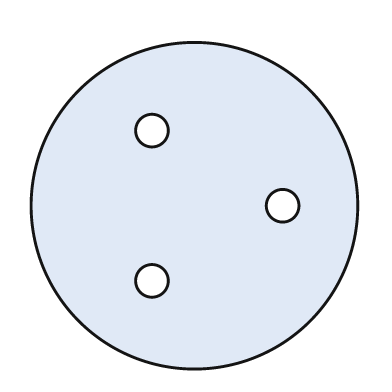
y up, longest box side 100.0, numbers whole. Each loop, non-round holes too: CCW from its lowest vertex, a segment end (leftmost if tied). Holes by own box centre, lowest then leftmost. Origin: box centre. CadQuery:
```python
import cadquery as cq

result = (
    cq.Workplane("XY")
    .moveTo(0.0, 0.0)
    .circle(50.0)
    .moveTo(-13.0, -23.0)
    .circle(5.0)
    .moveTo(27.0, 0.0)
    .circle(5.0)
    .moveTo(-13.0, 23.0)
    .circle(5.0)
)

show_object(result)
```